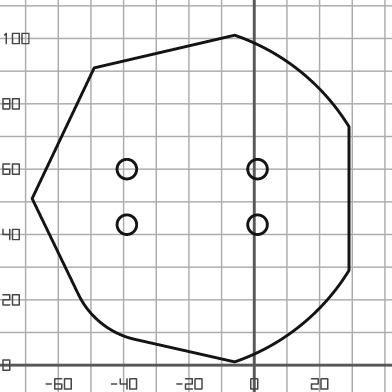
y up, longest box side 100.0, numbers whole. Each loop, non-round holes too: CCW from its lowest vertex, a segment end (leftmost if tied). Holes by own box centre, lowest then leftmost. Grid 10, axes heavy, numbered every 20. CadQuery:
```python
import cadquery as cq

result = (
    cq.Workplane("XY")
    .moveTo(-6.0, 1.0)
    .threePointArc((14.0, 12.0), (29.0, 29.0))
    .lineTo(29.0, 73.0)
    .threePointArc((14.0, 90.0), (-6.0, 101.0))
    .lineTo(-49.0, 91.0)
    .lineTo(-68.0, 51.0)
    .lineTo(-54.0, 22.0)
    .threePointArc((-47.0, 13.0), (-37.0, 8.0))
    .close()
    .moveTo(-39.0, 43.0)
    .circle(3.0)
    .moveTo(1.0, 43.0)
    .circle(3.0)
    .moveTo(-39.0, 60.0)
    .circle(3.0)
    .moveTo(1.0, 60.0)
    .circle(3.0)
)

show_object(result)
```